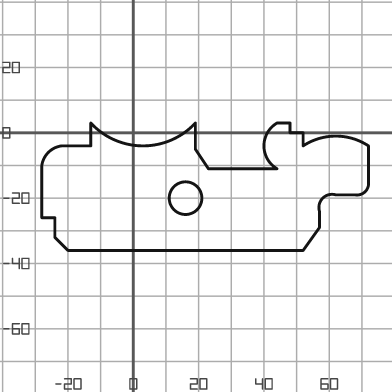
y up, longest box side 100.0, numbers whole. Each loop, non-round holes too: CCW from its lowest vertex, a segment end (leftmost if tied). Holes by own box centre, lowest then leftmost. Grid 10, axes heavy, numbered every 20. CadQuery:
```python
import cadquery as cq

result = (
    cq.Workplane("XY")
    .moveTo(-20.0, -36.0)
    .lineTo(52.0, -36.0)
    .lineTo(57.0, -29.0)
    .lineTo(57.0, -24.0)
    .threePointArc((58.0, -20.0), (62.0, -19.0))
    .lineTo(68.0, -19.0)
    .threePointArc((71.0, -18.0), (72.0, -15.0))
    .lineTo(72.0, -4.0)
    .threePointArc((62.0, -1.0), (52.0, -4.0))
    .lineTo(52.0, 0.0)
    .lineTo(48.0, 0.0)
    .lineTo(48.0, 3.0)
    .lineTo(44.0, 3.0)
    .threePointArc((40.0, -4.0), (44.0, -11.0))
    .lineTo(23.0, -11.0)
    .lineTo(19.0, -5.0)
    .lineTo(19.0, 3.0)
    .threePointArc((3.0, -4.0), (-13.0, 3.0))
    .lineTo(-13.0, -4.0)
    .lineTo(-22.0, -4.0)
    .threePointArc((-26.0, -6.0), (-28.0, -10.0))
    .lineTo(-28.0, -26.0)
    .lineTo(-24.0, -26.0)
    .lineTo(-24.0, -32.0)
    .close()
    .moveTo(16.0, -20.0)
    .circle(5.0)
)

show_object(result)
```